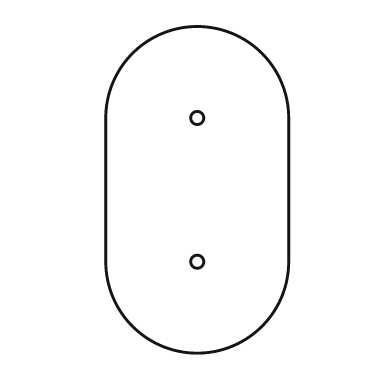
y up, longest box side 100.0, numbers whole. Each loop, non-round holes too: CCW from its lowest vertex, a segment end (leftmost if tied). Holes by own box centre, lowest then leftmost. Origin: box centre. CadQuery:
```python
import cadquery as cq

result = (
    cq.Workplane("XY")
    .moveTo(-28.0, -22.0)
    .threePointArc((0.0, -50.0), (28.0, -22.0))
    .lineTo(28.0, 22.0)
    .threePointArc((0.0, 50.0), (-28.0, 22.0))
    .close()
    .moveTo(0.0, -22.0)
    .circle(2.0)
    .moveTo(0.0, 22.0)
    .circle(2.0)
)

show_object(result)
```